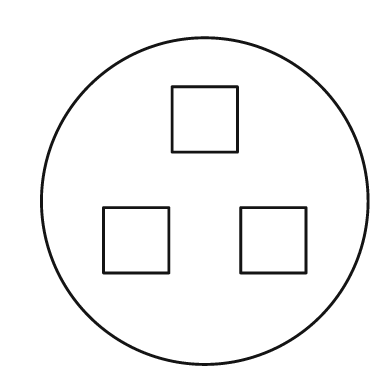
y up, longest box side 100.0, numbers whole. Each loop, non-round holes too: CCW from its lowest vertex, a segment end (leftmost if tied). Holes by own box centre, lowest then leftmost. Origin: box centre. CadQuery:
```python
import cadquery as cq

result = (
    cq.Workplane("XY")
    .moveTo(0.0, 0.0)
    .circle(50.0)
    .moveTo(-31.0, -22.0)
    .lineTo(-11.0, -22.0)
    .lineTo(-11.0, -2.0)
    .lineTo(-31.0, -2.0)
    .close()
    .moveTo(11.0, -22.0)
    .lineTo(31.0, -22.0)
    .lineTo(31.0, -2.0)
    .lineTo(11.0, -2.0)
    .close()
    .moveTo(-10.0, 15.0)
    .lineTo(10.0, 15.0)
    .lineTo(10.0, 35.0)
    .lineTo(-10.0, 35.0)
    .close()
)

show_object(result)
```